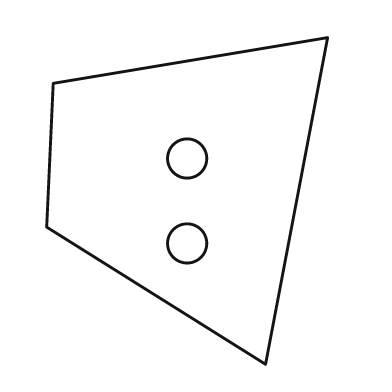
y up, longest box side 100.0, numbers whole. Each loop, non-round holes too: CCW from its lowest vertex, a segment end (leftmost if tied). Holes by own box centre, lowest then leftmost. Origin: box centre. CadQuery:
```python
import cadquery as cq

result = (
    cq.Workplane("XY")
    .moveTo(24.0, -50.0)
    .lineTo(43.0, 50.0)
    .lineTo(-41.0, 36.0)
    .lineTo(-43.0, -8.0)
    .close()
    .moveTo(0.0, -13.0)
    .circle(6.0)
    .moveTo(0.0, 13.0)
    .circle(6.0)
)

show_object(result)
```